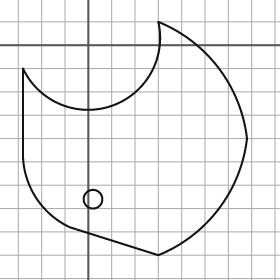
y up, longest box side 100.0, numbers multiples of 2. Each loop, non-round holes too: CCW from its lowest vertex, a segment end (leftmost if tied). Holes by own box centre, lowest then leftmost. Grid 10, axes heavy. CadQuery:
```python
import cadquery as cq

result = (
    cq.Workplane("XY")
    .moveTo(30.0, -90.0)
    .threePointArc((56.0, -70.0), (68.0, -40.0))
    .threePointArc((56.0, -10.0), (30.0, 10.0))
    .threePointArc((10.0, -26.0), (-28.0, -10.0))
    .lineTo(-28.0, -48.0)
    .threePointArc((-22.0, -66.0), (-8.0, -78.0))
    .close()
    .moveTo(2.0, -66.0)
    .circle(4.0)
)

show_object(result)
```